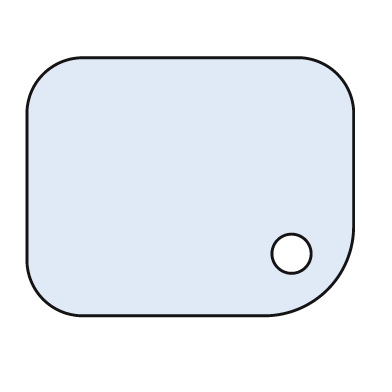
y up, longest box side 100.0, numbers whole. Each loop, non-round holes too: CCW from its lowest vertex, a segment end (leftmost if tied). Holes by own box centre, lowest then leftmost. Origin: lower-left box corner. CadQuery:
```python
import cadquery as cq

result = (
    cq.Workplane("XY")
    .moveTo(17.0, 0.0)
    .lineTo(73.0, 0.0)
    .threePointArc((92.0, 8.0), (100.0, 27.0))
    .lineTo(100.0, 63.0)
    .threePointArc((95.0, 74.0), (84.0, 79.0))
    .lineTo(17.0, 79.0)
    .threePointArc((5.0, 74.0), (0.0, 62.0))
    .lineTo(0.0, 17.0)
    .threePointArc((5.0, 5.0), (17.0, 0.0))
    .close()
    .moveTo(81.0, 19.0)
    .circle(6.0)
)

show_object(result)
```